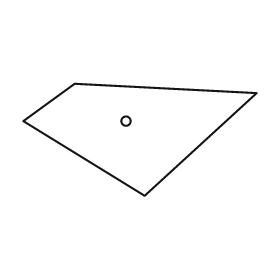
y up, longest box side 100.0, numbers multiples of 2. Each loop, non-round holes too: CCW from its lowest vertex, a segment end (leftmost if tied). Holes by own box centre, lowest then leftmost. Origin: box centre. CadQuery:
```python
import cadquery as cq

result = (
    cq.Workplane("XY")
    .moveTo(2.0, -24.0)
    .lineTo(50.0, 20.0)
    .lineTo(-28.0, 24.0)
    .lineTo(-50.0, 8.0)
    .close()
    .moveTo(-6.0, 8.0)
    .circle(2.0)
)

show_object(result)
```